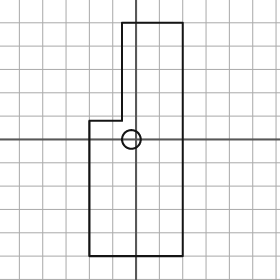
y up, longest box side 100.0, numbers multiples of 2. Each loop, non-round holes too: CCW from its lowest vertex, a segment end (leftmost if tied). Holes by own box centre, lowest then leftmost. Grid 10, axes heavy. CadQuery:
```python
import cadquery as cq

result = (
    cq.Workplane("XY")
    .moveTo(-20.0, -50.0)
    .lineTo(20.0, -50.0)
    .lineTo(20.0, 50.0)
    .lineTo(-6.0, 50.0)
    .lineTo(-6.0, 8.0)
    .lineTo(-20.0, 8.0)
    .close()
    .moveTo(-2.0, 0.0)
    .circle(4.0)
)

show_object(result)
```